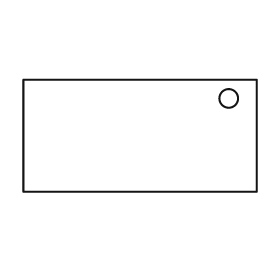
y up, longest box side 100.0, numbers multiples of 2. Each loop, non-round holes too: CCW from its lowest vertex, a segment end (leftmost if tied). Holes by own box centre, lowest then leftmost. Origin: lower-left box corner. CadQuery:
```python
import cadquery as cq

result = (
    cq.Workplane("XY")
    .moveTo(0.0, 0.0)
    .lineTo(100.0, 0.0)
    .lineTo(100.0, 48.0)
    .lineTo(0.0, 48.0)
    .close()
    .moveTo(88.0, 40.0)
    .circle(4.0)
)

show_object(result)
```